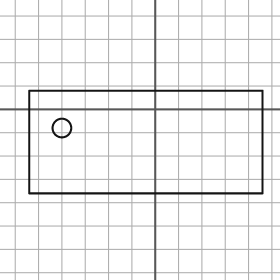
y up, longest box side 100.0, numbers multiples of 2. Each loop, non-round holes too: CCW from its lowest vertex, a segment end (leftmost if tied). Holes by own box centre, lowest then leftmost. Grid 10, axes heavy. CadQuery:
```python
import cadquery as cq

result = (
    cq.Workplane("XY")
    .moveTo(-54.0, -36.0)
    .lineTo(46.0, -36.0)
    .lineTo(46.0, 8.0)
    .lineTo(-54.0, 8.0)
    .close()
    .moveTo(-40.0, -8.0)
    .circle(4.0)
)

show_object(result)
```